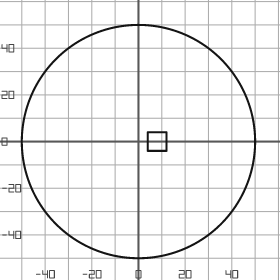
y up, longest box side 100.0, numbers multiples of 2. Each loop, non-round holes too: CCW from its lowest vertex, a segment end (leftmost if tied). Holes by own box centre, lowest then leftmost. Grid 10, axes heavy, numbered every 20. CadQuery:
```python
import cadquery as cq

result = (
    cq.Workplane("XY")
    .moveTo(0.0, 0.0)
    .circle(50.0)
    .moveTo(4.0, -4.0)
    .lineTo(12.0, -4.0)
    .lineTo(12.0, 4.0)
    .lineTo(4.0, 4.0)
    .close()
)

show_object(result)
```